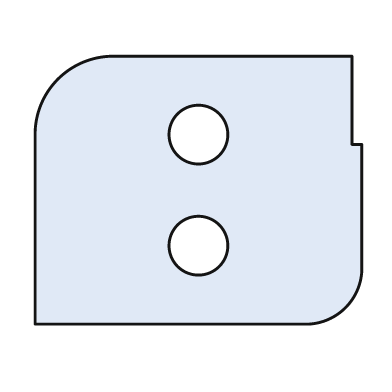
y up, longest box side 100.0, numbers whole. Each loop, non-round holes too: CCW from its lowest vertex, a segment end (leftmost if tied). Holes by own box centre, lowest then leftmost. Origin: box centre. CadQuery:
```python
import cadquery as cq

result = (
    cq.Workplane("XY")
    .moveTo(-50.0, -41.0)
    .lineTo(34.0, -41.0)
    .threePointArc((45.0, -36.0), (50.0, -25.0))
    .lineTo(50.0, 14.0)
    .lineTo(47.0, 14.0)
    .lineTo(47.0, 41.0)
    .lineTo(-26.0, 41.0)
    .threePointArc((-43.0, 34.0), (-50.0, 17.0))
    .close()
    .moveTo(0.0, -17.0)
    .circle(9.0)
    .moveTo(0.0, 17.0)
    .circle(9.0)
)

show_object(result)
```